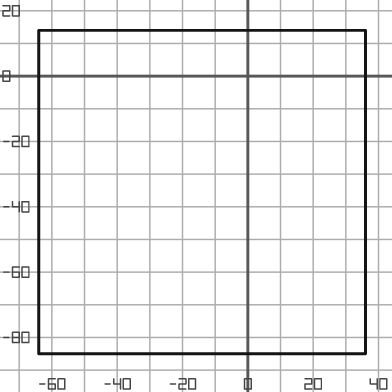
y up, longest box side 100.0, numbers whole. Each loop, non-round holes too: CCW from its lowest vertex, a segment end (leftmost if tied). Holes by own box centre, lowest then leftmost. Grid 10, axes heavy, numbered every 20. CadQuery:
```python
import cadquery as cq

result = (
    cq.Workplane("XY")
    .moveTo(-64.0, -85.0)
    .lineTo(36.0, -85.0)
    .lineTo(36.0, 14.0)
    .lineTo(-64.0, 14.0)
    .close()
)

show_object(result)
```